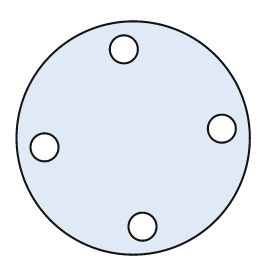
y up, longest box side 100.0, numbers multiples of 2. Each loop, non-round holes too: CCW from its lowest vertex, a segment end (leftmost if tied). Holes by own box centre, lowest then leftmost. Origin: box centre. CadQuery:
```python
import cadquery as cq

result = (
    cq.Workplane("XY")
    .moveTo(0.0, 0.0)
    .circle(50.0)
    .moveTo(4.0, -38.0)
    .circle(6.0)
    .moveTo(-38.0, -4.0)
    .circle(6.0)
    .moveTo(38.0, 4.0)
    .circle(6.0)
    .moveTo(-4.0, 38.0)
    .circle(6.0)
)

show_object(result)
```